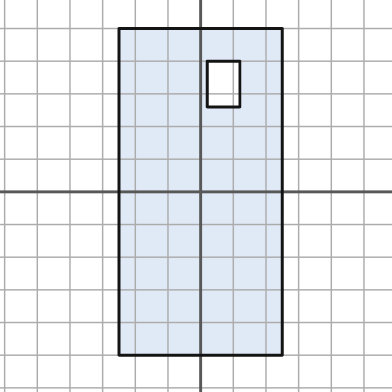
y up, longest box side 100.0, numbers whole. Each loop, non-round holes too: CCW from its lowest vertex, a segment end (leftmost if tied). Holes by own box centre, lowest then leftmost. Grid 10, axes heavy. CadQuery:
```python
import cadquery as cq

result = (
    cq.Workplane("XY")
    .moveTo(-25.0, -50.0)
    .lineTo(25.0, -50.0)
    .lineTo(25.0, 50.0)
    .lineTo(-25.0, 50.0)
    .close()
    .moveTo(2.0, 26.0)
    .lineTo(12.0, 26.0)
    .lineTo(12.0, 40.0)
    .lineTo(2.0, 40.0)
    .close()
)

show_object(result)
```